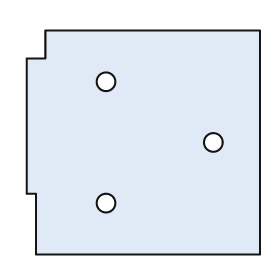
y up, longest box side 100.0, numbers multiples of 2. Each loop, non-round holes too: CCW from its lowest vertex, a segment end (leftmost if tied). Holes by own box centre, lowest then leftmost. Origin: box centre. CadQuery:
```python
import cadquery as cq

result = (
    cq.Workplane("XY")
    .moveTo(-46.0, -48.0)
    .lineTo(50.0, -48.0)
    .lineTo(50.0, 48.0)
    .lineTo(-42.0, 48.0)
    .lineTo(-42.0, 36.0)
    .lineTo(-50.0, 36.0)
    .lineTo(-50.0, -22.0)
    .lineTo(-46.0, -22.0)
    .close()
    .moveTo(-16.0, -26.0)
    .circle(4.0)
    .moveTo(30.0, 0.0)
    .circle(4.0)
    .moveTo(-16.0, 26.0)
    .circle(4.0)
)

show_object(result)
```